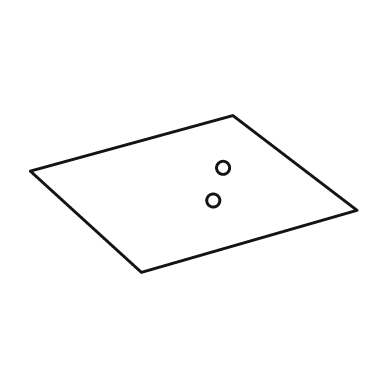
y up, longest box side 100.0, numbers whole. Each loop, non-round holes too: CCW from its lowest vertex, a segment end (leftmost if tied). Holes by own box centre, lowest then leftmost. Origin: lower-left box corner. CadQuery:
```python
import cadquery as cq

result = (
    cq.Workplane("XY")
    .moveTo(34.0, 0.0)
    .lineTo(100.0, 19.0)
    .lineTo(62.0, 48.0)
    .lineTo(0.0, 31.0)
    .close()
    .moveTo(56.0, 22.0)
    .circle(2.0)
    .moveTo(59.0, 32.0)
    .circle(2.0)
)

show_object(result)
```